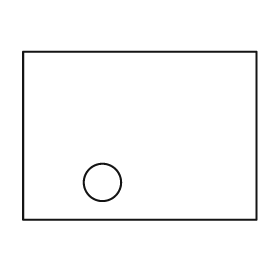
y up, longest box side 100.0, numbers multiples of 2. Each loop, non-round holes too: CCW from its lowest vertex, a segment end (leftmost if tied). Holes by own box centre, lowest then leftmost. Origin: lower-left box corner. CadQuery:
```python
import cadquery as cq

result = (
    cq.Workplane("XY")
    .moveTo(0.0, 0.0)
    .lineTo(100.0, 0.0)
    .lineTo(100.0, 72.0)
    .lineTo(0.0, 72.0)
    .close()
    .moveTo(34.0, 16.0)
    .circle(8.0)
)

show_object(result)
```